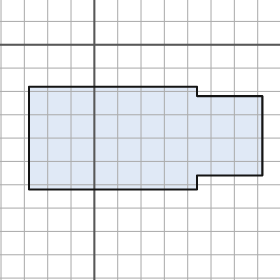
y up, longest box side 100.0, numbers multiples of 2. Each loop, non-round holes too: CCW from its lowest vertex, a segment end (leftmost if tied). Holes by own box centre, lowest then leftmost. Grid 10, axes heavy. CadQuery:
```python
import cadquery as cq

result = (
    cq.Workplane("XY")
    .moveTo(-28.0, -62.0)
    .lineTo(44.0, -62.0)
    .lineTo(44.0, -56.0)
    .lineTo(72.0, -56.0)
    .lineTo(72.0, -22.0)
    .lineTo(44.0, -22.0)
    .lineTo(44.0, -18.0)
    .lineTo(-28.0, -18.0)
    .close()
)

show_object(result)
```